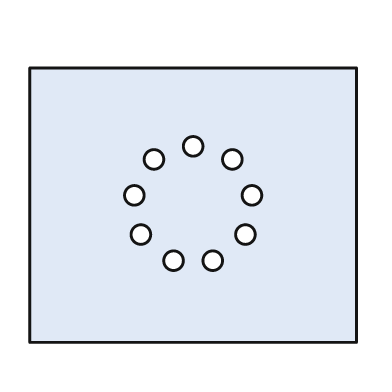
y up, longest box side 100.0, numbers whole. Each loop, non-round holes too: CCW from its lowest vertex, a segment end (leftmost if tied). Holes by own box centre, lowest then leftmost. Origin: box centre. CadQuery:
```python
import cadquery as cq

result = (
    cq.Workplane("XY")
    .moveTo(-50.0, -42.0)
    .lineTo(50.0, -42.0)
    .lineTo(50.0, 42.0)
    .lineTo(-50.0, 42.0)
    .close()
    .moveTo(-6.0, -17.0)
    .circle(3.0)
    .moveTo(6.0, -17.0)
    .circle(3.0)
    .moveTo(-16.0, -9.0)
    .circle(3.0)
    .moveTo(16.0, -9.0)
    .circle(3.0)
    .moveTo(-18.0, 3.0)
    .circle(3.0)
    .moveTo(18.0, 3.0)
    .circle(3.0)
    .moveTo(-12.0, 14.0)
    .circle(3.0)
    .moveTo(12.0, 14.0)
    .circle(3.0)
    .moveTo(0.0, 18.0)
    .circle(3.0)
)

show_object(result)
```